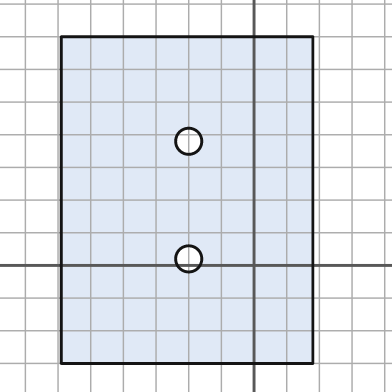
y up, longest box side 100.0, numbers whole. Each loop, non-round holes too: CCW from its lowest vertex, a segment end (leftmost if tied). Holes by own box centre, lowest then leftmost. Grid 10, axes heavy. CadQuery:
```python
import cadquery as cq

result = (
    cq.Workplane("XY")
    .moveTo(-59.0, -30.0)
    .lineTo(18.0, -30.0)
    .lineTo(18.0, 70.0)
    .lineTo(-59.0, 70.0)
    .close()
    .moveTo(-20.0, 2.0)
    .circle(4.0)
    .moveTo(-20.0, 38.0)
    .circle(4.0)
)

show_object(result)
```